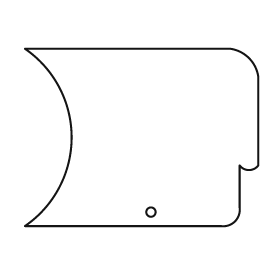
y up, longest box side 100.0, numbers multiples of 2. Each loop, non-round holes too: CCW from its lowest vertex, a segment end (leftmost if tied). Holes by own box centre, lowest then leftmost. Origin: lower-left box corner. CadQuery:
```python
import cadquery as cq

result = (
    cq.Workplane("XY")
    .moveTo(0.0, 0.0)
    .lineTo(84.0, 0.0)
    .threePointArc((90.0, 2.0), (92.0, 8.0))
    .lineTo(92.0, 26.0)
    .threePointArc((96.0, 24.0), (100.0, 26.0))
    .lineTo(100.0, 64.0)
    .threePointArc((96.0, 72.0), (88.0, 76.0))
    .lineTo(0.0, 76.0)
    .threePointArc((20.0, 38.0), (0.0, 0.0))
    .close()
    .moveTo(54.0, 6.0)
    .circle(2.0)
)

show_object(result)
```